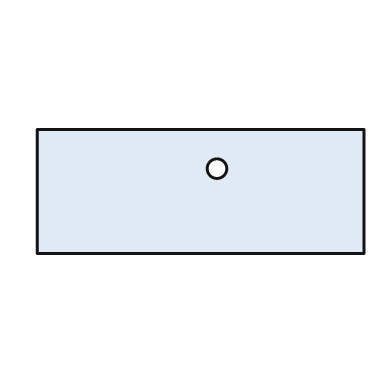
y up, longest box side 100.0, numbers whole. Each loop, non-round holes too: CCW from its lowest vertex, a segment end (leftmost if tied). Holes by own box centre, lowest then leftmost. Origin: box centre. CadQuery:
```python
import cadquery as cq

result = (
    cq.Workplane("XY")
    .moveTo(-50.0, -19.0)
    .lineTo(50.0, -19.0)
    .lineTo(50.0, 19.0)
    .lineTo(-50.0, 19.0)
    .close()
    .moveTo(5.0, 7.0)
    .circle(3.0)
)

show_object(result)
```